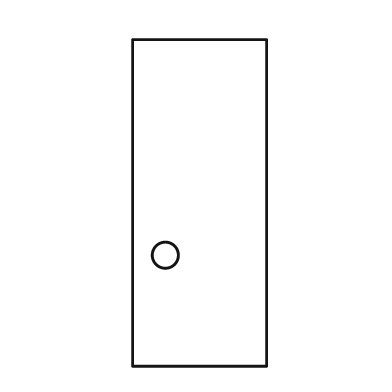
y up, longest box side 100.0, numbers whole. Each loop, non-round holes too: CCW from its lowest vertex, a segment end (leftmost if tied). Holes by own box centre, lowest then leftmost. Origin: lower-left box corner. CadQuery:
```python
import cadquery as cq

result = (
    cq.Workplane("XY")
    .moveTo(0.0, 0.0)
    .lineTo(41.0, 0.0)
    .lineTo(41.0, 100.0)
    .lineTo(0.0, 100.0)
    .close()
    .moveTo(10.0, 34.0)
    .circle(4.0)
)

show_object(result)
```